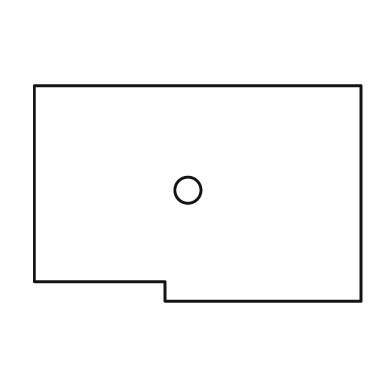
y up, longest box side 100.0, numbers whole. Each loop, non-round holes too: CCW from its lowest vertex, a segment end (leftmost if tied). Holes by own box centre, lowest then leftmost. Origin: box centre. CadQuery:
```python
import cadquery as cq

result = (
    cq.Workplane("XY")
    .moveTo(-10.0, -33.0)
    .lineTo(50.0, -33.0)
    .lineTo(50.0, 33.0)
    .lineTo(-50.0, 33.0)
    .lineTo(-50.0, -27.0)
    .lineTo(-10.0, -27.0)
    .close()
    .moveTo(-3.0, 1.0)
    .circle(4.0)
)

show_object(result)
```